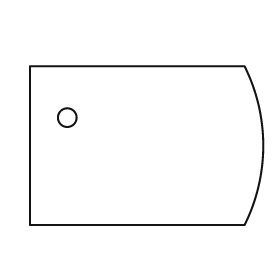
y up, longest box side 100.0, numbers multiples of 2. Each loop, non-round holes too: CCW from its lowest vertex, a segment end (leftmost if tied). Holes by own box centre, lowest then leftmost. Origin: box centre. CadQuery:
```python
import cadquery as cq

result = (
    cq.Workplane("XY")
    .moveTo(-50.0, -34.0)
    .lineTo(42.0, -34.0)
    .threePointArc((50.0, 0.0), (42.0, 34.0))
    .lineTo(-50.0, 34.0)
    .close()
    .moveTo(-34.0, 12.0)
    .circle(4.0)
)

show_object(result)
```